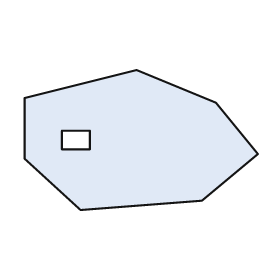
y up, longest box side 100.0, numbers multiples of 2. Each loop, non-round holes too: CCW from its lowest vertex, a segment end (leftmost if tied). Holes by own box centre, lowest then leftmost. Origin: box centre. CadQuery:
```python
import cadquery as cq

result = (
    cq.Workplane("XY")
    .moveTo(-26.0, -30.0)
    .lineTo(26.0, -26.0)
    .lineTo(50.0, -6.0)
    .lineTo(32.0, 16.0)
    .lineTo(-2.0, 30.0)
    .lineTo(-50.0, 18.0)
    .lineTo(-50.0, -8.0)
    .close()
    .moveTo(-34.0, -4.0)
    .lineTo(-22.0, -4.0)
    .lineTo(-22.0, 4.0)
    .lineTo(-34.0, 4.0)
    .close()
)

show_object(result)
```